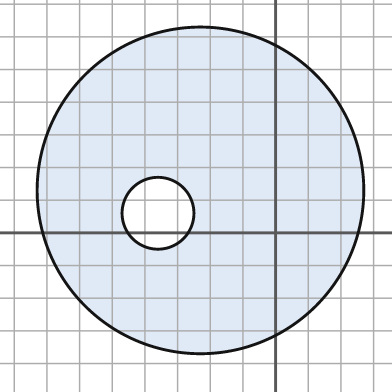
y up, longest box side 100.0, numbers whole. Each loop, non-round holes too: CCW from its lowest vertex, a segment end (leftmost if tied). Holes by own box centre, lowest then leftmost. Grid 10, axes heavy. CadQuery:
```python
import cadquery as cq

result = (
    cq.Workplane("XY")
    .moveTo(-23.0, 13.0)
    .circle(50.0)
    .moveTo(-36.0, 6.0)
    .circle(11.0)
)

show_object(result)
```